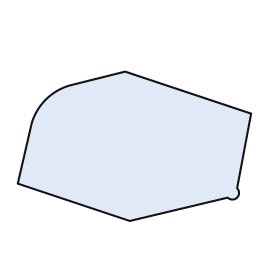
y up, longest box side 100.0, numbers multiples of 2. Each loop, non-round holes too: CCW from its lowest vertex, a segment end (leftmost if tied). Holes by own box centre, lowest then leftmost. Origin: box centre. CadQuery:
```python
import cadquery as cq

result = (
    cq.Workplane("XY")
    .moveTo(-2.0, -32.0)
    .lineTo(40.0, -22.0)
    .threePointArc((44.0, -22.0), (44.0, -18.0))
    .lineTo(50.0, 14.0)
    .lineTo(-4.0, 32.0)
    .lineTo(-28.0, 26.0)
    .threePointArc((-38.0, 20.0), (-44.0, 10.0))
    .lineTo(-50.0, -16.0)
    .close()
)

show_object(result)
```